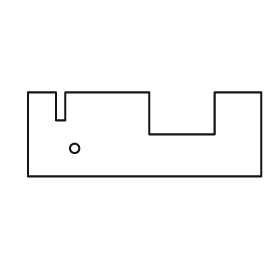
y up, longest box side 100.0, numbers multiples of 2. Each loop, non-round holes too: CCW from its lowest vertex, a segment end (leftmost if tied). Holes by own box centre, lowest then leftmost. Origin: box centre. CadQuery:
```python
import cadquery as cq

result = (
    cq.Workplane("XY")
    .moveTo(-50.0, -18.0)
    .lineTo(50.0, -18.0)
    .lineTo(50.0, 18.0)
    .lineTo(30.0, 18.0)
    .lineTo(30.0, 0.0)
    .lineTo(2.0, 0.0)
    .lineTo(2.0, 18.0)
    .lineTo(-34.0, 18.0)
    .lineTo(-34.0, 6.0)
    .lineTo(-38.0, 6.0)
    .lineTo(-38.0, 18.0)
    .lineTo(-50.0, 18.0)
    .close()
    .moveTo(-30.0, -6.0)
    .circle(2.0)
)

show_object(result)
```